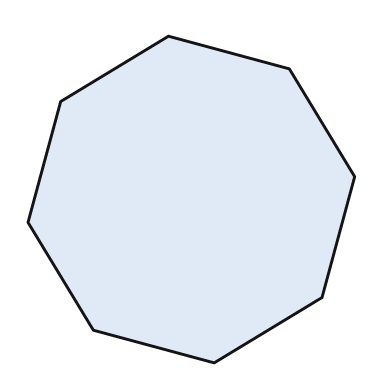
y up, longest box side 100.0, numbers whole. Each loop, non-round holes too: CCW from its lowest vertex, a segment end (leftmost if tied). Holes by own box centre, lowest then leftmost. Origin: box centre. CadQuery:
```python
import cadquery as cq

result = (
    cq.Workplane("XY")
    .moveTo(7.0, -50.0)
    .lineTo(40.0, -30.0)
    .lineTo(50.0, 7.0)
    .lineTo(30.0, 40.0)
    .lineTo(-7.0, 50.0)
    .lineTo(-40.0, 30.0)
    .lineTo(-50.0, -7.0)
    .lineTo(-30.0, -40.0)
    .close()
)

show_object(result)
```